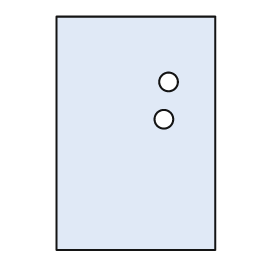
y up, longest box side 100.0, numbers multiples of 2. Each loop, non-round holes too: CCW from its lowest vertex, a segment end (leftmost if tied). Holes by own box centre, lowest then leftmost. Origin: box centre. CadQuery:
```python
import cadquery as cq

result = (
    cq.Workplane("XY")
    .moveTo(-34.0, -50.0)
    .lineTo(34.0, -50.0)
    .lineTo(34.0, 50.0)
    .lineTo(-34.0, 50.0)
    .close()
    .moveTo(12.0, 6.0)
    .circle(4.0)
    .moveTo(14.0, 22.0)
    .circle(4.0)
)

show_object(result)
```